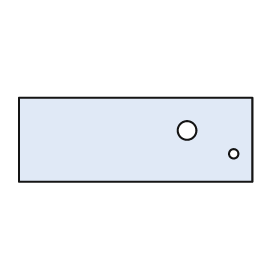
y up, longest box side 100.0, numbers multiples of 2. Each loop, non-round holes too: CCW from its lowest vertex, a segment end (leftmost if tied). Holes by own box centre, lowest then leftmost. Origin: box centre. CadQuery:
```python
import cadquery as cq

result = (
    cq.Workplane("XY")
    .moveTo(-50.0, -18.0)
    .lineTo(50.0, -18.0)
    .lineTo(50.0, 18.0)
    .lineTo(-50.0, 18.0)
    .close()
    .moveTo(42.0, -6.0)
    .circle(2.0)
    .moveTo(22.0, 4.0)
    .circle(4.0)
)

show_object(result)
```